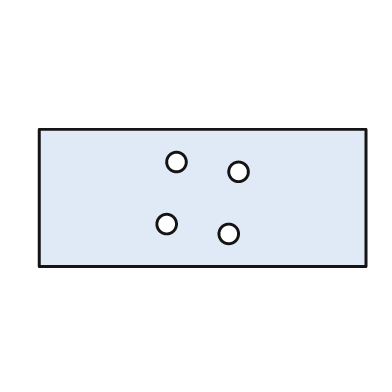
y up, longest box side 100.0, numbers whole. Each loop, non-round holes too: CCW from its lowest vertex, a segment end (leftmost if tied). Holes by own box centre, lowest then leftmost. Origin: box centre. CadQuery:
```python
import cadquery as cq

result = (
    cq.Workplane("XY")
    .moveTo(-50.0, -21.0)
    .lineTo(50.0, -21.0)
    .lineTo(50.0, 21.0)
    .lineTo(-50.0, 21.0)
    .close()
    .moveTo(8.0, -11.0)
    .circle(3.0)
    .moveTo(-11.0, -8.0)
    .circle(3.0)
    .moveTo(11.0, 8.0)
    .circle(3.0)
    .moveTo(-8.0, 11.0)
    .circle(3.0)
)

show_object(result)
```